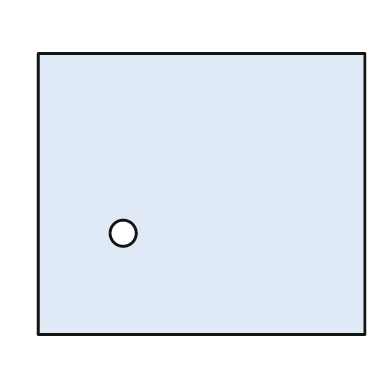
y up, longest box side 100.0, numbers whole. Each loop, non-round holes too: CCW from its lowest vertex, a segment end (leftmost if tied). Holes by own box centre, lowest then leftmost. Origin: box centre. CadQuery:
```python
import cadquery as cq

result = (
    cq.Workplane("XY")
    .moveTo(-50.0, -43.0)
    .lineTo(50.0, -43.0)
    .lineTo(50.0, 43.0)
    .lineTo(-50.0, 43.0)
    .close()
    .moveTo(-24.0, -12.0)
    .circle(4.0)
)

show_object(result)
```